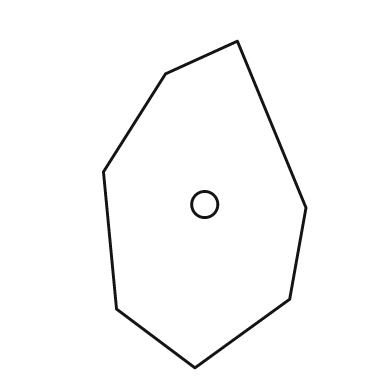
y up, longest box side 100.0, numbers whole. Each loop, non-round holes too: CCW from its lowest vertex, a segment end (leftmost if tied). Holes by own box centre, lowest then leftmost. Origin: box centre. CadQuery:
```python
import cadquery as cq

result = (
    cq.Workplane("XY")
    .moveTo(-3.0, -50.0)
    .lineTo(26.0, -29.0)
    .lineTo(31.0, -1.0)
    .lineTo(10.0, 50.0)
    .lineTo(-12.0, 40.0)
    .lineTo(-31.0, 10.0)
    .lineTo(-27.0, -32.0)
    .close()
    .moveTo(0.0, 0.0)
    .circle(4.0)
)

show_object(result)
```